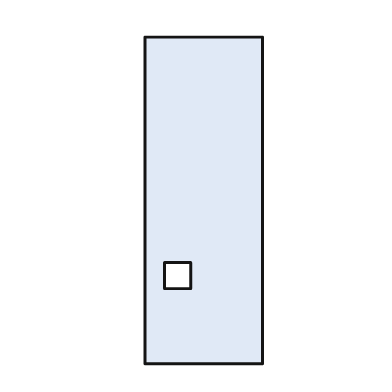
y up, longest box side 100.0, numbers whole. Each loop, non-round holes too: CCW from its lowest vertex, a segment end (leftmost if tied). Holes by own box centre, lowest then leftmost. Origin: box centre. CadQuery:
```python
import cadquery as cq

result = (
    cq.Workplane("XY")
    .moveTo(-18.0, -50.0)
    .lineTo(18.0, -50.0)
    .lineTo(18.0, 50.0)
    .lineTo(-18.0, 50.0)
    .close()
    .moveTo(-12.0, -27.0)
    .lineTo(-4.0, -27.0)
    .lineTo(-4.0, -19.0)
    .lineTo(-12.0, -19.0)
    .close()
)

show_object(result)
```